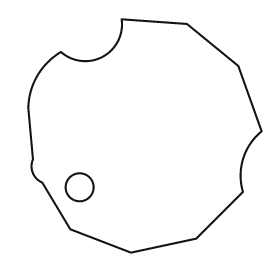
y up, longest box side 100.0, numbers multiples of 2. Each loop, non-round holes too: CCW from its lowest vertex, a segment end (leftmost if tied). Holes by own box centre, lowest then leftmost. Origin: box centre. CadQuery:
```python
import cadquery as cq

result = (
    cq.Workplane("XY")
    .moveTo(-6.0, -50.0)
    .lineTo(22.0, -44.0)
    .lineTo(42.0, -24.0)
    .threePointArc((42.0, -10.0), (50.0, 2.0))
    .lineTo(40.0, 30.0)
    .lineTo(18.0, 48.0)
    .lineTo(-10.0, 50.0)
    .threePointArc((-18.0, 34.0), (-36.0, 36.0))
    .threePointArc((-46.0, 26.0), (-50.0, 12.0))
    .lineTo(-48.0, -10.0)
    .threePointArc((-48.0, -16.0), (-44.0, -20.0))
    .lineTo(-32.0, -40.0)
    .close()
    .moveTo(-28.0, -22.0)
    .circle(6.0)
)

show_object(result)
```